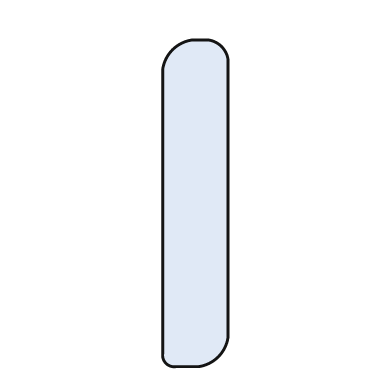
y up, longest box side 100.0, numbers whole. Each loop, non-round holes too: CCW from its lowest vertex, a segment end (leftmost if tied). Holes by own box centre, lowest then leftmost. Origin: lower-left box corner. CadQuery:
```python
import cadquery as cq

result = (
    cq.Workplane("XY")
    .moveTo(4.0, 0.0)
    .lineTo(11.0, 0.0)
    .threePointArc((17.0, 3.0), (20.0, 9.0))
    .lineTo(20.0, 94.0)
    .threePointArc((18.0, 98.0), (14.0, 100.0))
    .lineTo(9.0, 100.0)
    .threePointArc((3.0, 97.0), (0.0, 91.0))
    .lineTo(0.0, 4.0)
    .threePointArc((1.0, 1.0), (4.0, 0.0))
    .close()
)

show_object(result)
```